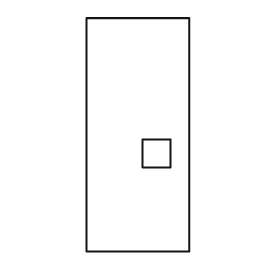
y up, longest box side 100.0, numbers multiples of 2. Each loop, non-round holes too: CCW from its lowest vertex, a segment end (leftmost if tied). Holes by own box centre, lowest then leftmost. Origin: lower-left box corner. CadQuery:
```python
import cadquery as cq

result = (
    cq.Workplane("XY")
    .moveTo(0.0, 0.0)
    .lineTo(44.0, 0.0)
    .lineTo(44.0, 100.0)
    .lineTo(0.0, 100.0)
    .close()
    .moveTo(24.0, 36.0)
    .lineTo(36.0, 36.0)
    .lineTo(36.0, 48.0)
    .lineTo(24.0, 48.0)
    .close()
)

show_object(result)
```